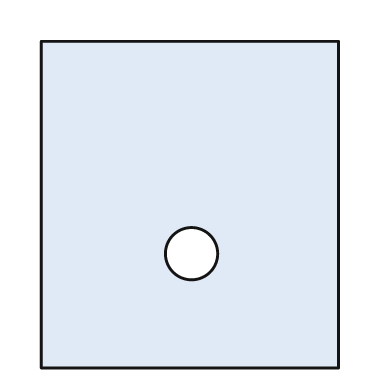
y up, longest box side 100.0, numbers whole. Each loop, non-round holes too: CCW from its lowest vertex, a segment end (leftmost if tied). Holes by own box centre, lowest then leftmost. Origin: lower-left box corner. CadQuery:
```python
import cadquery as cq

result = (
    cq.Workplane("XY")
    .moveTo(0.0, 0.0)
    .lineTo(91.0, 0.0)
    .lineTo(91.0, 100.0)
    .lineTo(0.0, 100.0)
    .close()
    .moveTo(46.0, 35.0)
    .circle(8.0)
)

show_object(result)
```